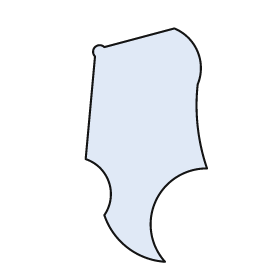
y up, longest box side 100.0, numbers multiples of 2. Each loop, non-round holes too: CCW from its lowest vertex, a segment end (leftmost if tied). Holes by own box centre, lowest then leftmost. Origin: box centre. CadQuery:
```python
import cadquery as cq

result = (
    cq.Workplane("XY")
    .moveTo(8.0, -50.0)
    .threePointArc((4.0, -24.0), (26.0, -10.0))
    .threePointArc((22.0, 8.0), (22.0, 26.0))
    .threePointArc((22.0, 40.0), (12.0, 50.0))
    .lineTo(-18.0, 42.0)
    .threePointArc((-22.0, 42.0), (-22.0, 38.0))
    .lineTo(-26.0, -6.0)
    .threePointArc((-16.0, -16.0), (-18.0, -30.0))
    .threePointArc((-8.0, -44.0), (8.0, -50.0))
    .close()
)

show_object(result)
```